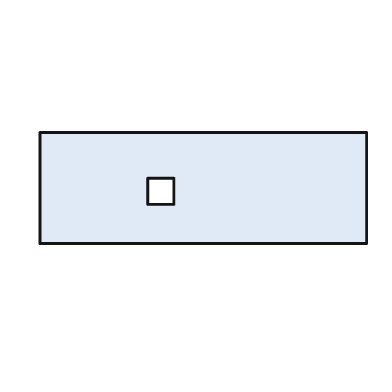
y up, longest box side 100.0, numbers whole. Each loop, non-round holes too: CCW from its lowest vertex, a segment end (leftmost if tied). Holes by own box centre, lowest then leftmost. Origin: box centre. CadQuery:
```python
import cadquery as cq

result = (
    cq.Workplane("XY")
    .moveTo(-50.0, -17.0)
    .lineTo(50.0, -17.0)
    .lineTo(50.0, 17.0)
    .lineTo(-50.0, 17.0)
    .close()
    .moveTo(-17.0, -5.0)
    .lineTo(-9.0, -5.0)
    .lineTo(-9.0, 3.0)
    .lineTo(-17.0, 3.0)
    .close()
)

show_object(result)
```